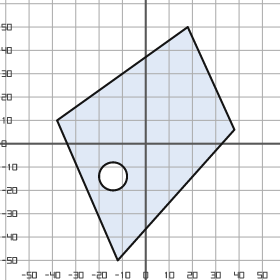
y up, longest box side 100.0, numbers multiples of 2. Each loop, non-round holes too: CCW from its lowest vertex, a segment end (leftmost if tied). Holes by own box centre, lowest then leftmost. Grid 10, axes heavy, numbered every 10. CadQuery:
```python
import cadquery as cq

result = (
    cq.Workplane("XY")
    .moveTo(-12.0, -50.0)
    .lineTo(38.0, 6.0)
    .lineTo(18.0, 50.0)
    .lineTo(-38.0, 10.0)
    .close()
    .moveTo(-14.0, -14.0)
    .circle(6.0)
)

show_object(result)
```